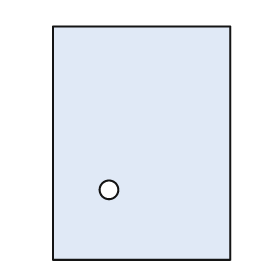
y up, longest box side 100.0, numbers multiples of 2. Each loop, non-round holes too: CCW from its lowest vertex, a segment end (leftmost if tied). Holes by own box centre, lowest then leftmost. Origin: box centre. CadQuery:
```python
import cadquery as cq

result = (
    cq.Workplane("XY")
    .moveTo(-38.0, -50.0)
    .lineTo(38.0, -50.0)
    .lineTo(38.0, 50.0)
    .lineTo(-38.0, 50.0)
    .close()
    .moveTo(-14.0, -20.0)
    .circle(4.0)
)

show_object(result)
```